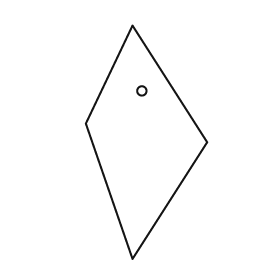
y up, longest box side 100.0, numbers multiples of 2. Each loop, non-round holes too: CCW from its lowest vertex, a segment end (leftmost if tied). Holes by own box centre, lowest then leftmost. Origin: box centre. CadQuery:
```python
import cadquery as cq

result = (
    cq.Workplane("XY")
    .moveTo(-6.0, -50.0)
    .lineTo(26.0, 0.0)
    .lineTo(-6.0, 50.0)
    .lineTo(-26.0, 8.0)
    .close()
    .moveTo(-2.0, 22.0)
    .circle(2.0)
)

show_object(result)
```